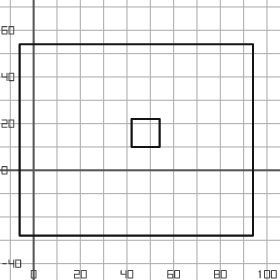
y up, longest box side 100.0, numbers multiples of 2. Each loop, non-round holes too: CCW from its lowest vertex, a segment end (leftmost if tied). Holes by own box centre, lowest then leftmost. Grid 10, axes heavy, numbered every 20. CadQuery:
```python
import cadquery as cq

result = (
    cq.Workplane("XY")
    .moveTo(-6.0, -28.0)
    .lineTo(94.0, -28.0)
    .lineTo(94.0, 54.0)
    .lineTo(-6.0, 54.0)
    .close()
    .moveTo(42.0, 10.0)
    .lineTo(54.0, 10.0)
    .lineTo(54.0, 22.0)
    .lineTo(42.0, 22.0)
    .close()
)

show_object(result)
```